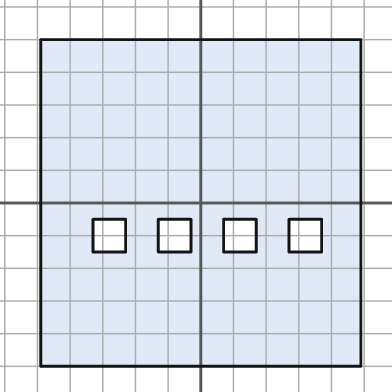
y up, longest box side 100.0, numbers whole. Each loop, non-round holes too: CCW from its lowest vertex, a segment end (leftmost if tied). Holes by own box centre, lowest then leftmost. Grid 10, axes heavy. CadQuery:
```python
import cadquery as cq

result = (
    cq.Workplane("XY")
    .moveTo(-49.0, -50.0)
    .lineTo(49.0, -50.0)
    .lineTo(49.0, 50.0)
    .lineTo(-49.0, 50.0)
    .close()
    .moveTo(-33.0, -15.0)
    .lineTo(-23.0, -15.0)
    .lineTo(-23.0, -5.0)
    .lineTo(-33.0, -5.0)
    .close()
    .moveTo(-13.0, -15.0)
    .lineTo(-3.0, -15.0)
    .lineTo(-3.0, -5.0)
    .lineTo(-13.0, -5.0)
    .close()
    .moveTo(7.0, -15.0)
    .lineTo(17.0, -15.0)
    .lineTo(17.0, -5.0)
    .lineTo(7.0, -5.0)
    .close()
    .moveTo(27.0, -15.0)
    .lineTo(37.0, -15.0)
    .lineTo(37.0, -5.0)
    .lineTo(27.0, -5.0)
    .close()
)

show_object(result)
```